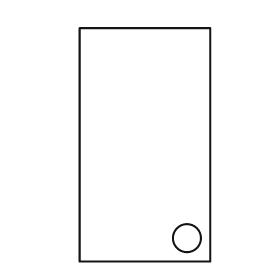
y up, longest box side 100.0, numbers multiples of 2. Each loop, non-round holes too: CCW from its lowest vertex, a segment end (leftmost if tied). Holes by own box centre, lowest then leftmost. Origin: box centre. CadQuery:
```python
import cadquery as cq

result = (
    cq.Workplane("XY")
    .moveTo(-28.0, -50.0)
    .lineTo(28.0, -50.0)
    .lineTo(28.0, 50.0)
    .lineTo(-28.0, 50.0)
    .close()
    .moveTo(18.0, -40.0)
    .circle(6.0)
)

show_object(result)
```